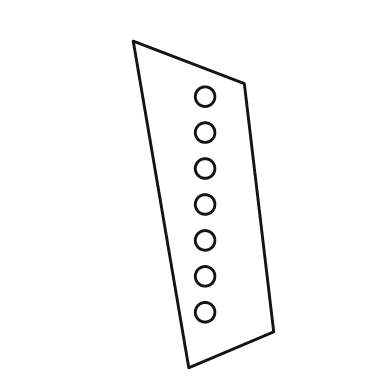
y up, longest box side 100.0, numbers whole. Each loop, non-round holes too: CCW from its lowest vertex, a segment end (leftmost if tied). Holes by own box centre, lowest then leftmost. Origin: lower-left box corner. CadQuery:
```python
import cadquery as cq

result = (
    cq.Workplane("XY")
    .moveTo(17.0, 0.0)
    .lineTo(43.0, 11.0)
    .lineTo(34.0, 87.0)
    .lineTo(0.0, 100.0)
    .close()
    .moveTo(22.0, 17.0)
    .circle(3.0)
    .moveTo(22.0, 28.0)
    .circle(3.0)
    .moveTo(22.0, 39.0)
    .circle(3.0)
    .moveTo(22.0, 50.0)
    .circle(3.0)
    .moveTo(22.0, 61.0)
    .circle(3.0)
    .moveTo(22.0, 72.0)
    .circle(3.0)
    .moveTo(22.0, 83.0)
    .circle(3.0)
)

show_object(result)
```